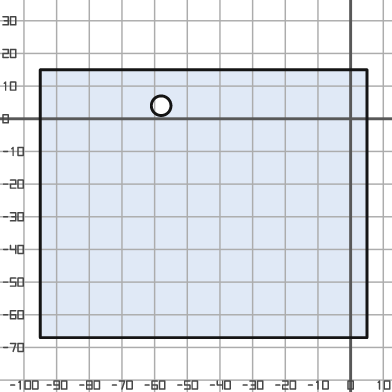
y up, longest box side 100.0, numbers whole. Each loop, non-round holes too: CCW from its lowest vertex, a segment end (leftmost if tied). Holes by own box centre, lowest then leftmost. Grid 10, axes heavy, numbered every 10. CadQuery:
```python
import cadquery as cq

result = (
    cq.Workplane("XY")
    .moveTo(-95.0, -67.0)
    .lineTo(5.0, -67.0)
    .lineTo(5.0, 15.0)
    .lineTo(-95.0, 15.0)
    .close()
    .moveTo(-58.0, 4.0)
    .circle(3.0)
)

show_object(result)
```